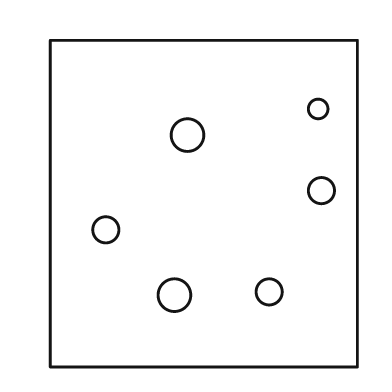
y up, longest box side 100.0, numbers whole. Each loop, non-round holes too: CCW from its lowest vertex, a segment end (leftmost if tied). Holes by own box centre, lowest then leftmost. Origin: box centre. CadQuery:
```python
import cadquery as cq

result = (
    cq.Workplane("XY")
    .moveTo(-47.0, -50.0)
    .lineTo(47.0, -50.0)
    .lineTo(47.0, 50.0)
    .lineTo(-47.0, 50.0)
    .close()
    .moveTo(-9.0, -28.0)
    .circle(5.0)
    .moveTo(20.0, -27.0)
    .circle(4.0)
    .moveTo(-30.0, -8.0)
    .circle(4.0)
    .moveTo(36.0, 4.0)
    .circle(4.0)
    .moveTo(-5.0, 21.0)
    .circle(5.0)
    .moveTo(35.0, 29.0)
    .circle(3.0)
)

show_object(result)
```